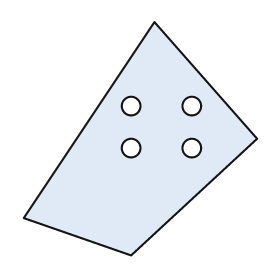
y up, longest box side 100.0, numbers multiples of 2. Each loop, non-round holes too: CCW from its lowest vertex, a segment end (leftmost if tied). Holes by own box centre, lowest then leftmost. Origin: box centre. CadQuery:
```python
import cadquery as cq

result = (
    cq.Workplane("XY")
    .moveTo(-4.0, -50.0)
    .lineTo(50.0, 0.0)
    .lineTo(6.0, 50.0)
    .lineTo(-50.0, -34.0)
    .close()
    .moveTo(-4.0, -4.0)
    .circle(4.0)
    .moveTo(22.0, -4.0)
    .circle(4.0)
    .moveTo(-4.0, 14.0)
    .circle(4.0)
    .moveTo(22.0, 14.0)
    .circle(4.0)
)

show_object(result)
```